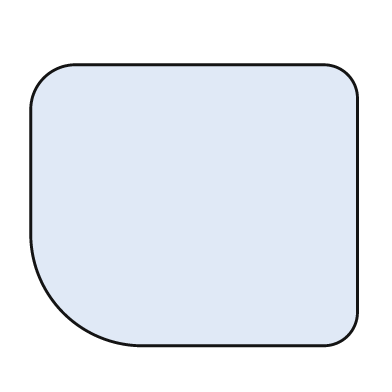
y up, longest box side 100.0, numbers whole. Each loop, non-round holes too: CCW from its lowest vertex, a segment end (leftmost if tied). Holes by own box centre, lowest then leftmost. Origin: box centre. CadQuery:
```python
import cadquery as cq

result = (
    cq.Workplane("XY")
    .moveTo(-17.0, -43.0)
    .lineTo(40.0, -43.0)
    .threePointArc((47.0, -40.0), (50.0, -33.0))
    .lineTo(50.0, 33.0)
    .threePointArc((47.0, 40.0), (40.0, 43.0))
    .lineTo(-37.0, 43.0)
    .threePointArc((-46.0, 39.0), (-50.0, 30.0))
    .lineTo(-50.0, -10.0)
    .threePointArc((-40.0, -33.0), (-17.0, -43.0))
    .close()
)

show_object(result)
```